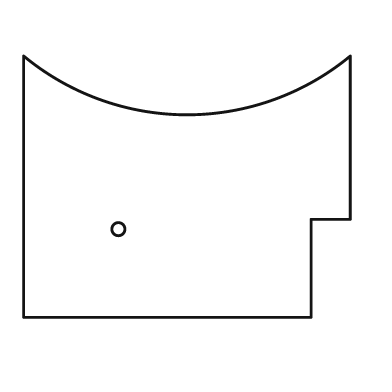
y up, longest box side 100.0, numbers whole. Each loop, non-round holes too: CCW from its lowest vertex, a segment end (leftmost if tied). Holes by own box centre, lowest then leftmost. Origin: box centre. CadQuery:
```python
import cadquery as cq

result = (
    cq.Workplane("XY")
    .moveTo(-50.0, -40.0)
    .lineTo(38.0, -40.0)
    .lineTo(38.0, -10.0)
    .lineTo(50.0, -10.0)
    .lineTo(50.0, 40.0)
    .threePointArc((0.0, 22.0), (-50.0, 40.0))
    .close()
    .moveTo(-21.0, -13.0)
    .circle(2.0)
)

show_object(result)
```